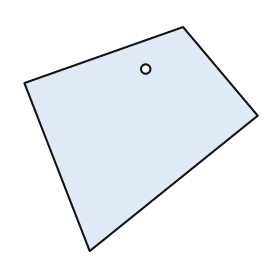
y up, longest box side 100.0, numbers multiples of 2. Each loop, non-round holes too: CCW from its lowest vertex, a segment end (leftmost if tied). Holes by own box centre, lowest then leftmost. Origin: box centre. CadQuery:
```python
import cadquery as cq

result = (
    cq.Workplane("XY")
    .moveTo(-22.0, -48.0)
    .lineTo(50.0, 10.0)
    .lineTo(18.0, 48.0)
    .lineTo(-50.0, 24.0)
    .close()
    .moveTo(2.0, 30.0)
    .circle(2.0)
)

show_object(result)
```